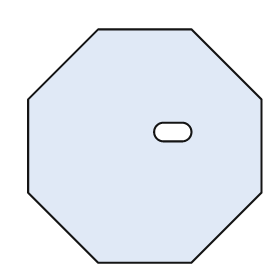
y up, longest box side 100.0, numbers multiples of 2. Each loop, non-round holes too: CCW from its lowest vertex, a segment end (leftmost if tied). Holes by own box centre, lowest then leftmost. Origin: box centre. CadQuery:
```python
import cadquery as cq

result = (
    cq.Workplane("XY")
    .moveTo(-20.0, -50.0)
    .lineTo(20.0, -50.0)
    .lineTo(50.0, -20.0)
    .lineTo(50.0, 20.0)
    .lineTo(20.0, 50.0)
    .lineTo(-20.0, 50.0)
    .lineTo(-50.0, 20.0)
    .lineTo(-50.0, -20.0)
    .close()
    .moveTo(8.0, 2.0)
    .lineTo(16.0, 2.0)
    .threePointArc((20.0, 6.0), (16.0, 10.0))
    .lineTo(8.0, 10.0)
    .threePointArc((4.0, 6.0), (8.0, 2.0))
    .close()
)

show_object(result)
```